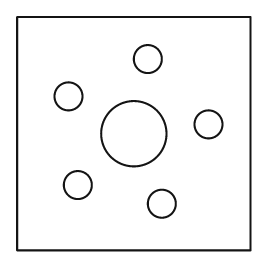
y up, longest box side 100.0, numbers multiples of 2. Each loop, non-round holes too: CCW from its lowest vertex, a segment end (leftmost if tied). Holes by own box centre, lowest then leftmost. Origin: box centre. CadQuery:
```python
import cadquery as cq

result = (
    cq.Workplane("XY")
    .moveTo(-50.0, -50.0)
    .lineTo(50.0, -50.0)
    .lineTo(50.0, 50.0)
    .lineTo(-50.0, 50.0)
    .close()
    .moveTo(12.0, -30.0)
    .circle(6.0)
    .moveTo(-24.0, -22.0)
    .circle(6.0)
    .moveTo(0.0, 0.0)
    .circle(14.0)
    .moveTo(32.0, 4.0)
    .circle(6.0)
    .moveTo(-28.0, 16.0)
    .circle(6.0)
    .moveTo(6.0, 32.0)
    .circle(6.0)
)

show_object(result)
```